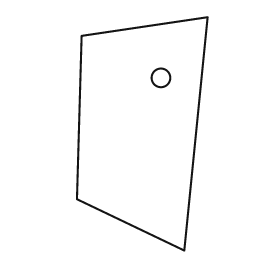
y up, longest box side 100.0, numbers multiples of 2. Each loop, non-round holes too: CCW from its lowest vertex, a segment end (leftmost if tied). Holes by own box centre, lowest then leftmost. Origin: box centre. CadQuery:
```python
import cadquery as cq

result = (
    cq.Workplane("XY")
    .moveTo(18.0, -50.0)
    .lineTo(28.0, 50.0)
    .lineTo(-26.0, 42.0)
    .lineTo(-28.0, -28.0)
    .close()
    .moveTo(8.0, 24.0)
    .circle(4.0)
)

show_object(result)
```